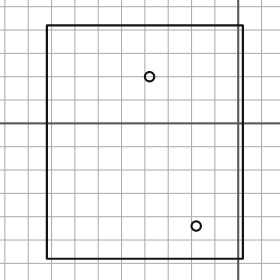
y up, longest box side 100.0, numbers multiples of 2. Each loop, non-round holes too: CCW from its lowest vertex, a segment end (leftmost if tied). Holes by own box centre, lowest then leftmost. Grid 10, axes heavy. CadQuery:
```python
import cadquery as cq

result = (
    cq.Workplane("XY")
    .moveTo(-82.0, -58.0)
    .lineTo(2.0, -58.0)
    .lineTo(2.0, 42.0)
    .lineTo(-82.0, 42.0)
    .close()
    .moveTo(-18.0, -44.0)
    .circle(2.0)
    .moveTo(-38.0, 20.0)
    .circle(2.0)
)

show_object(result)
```